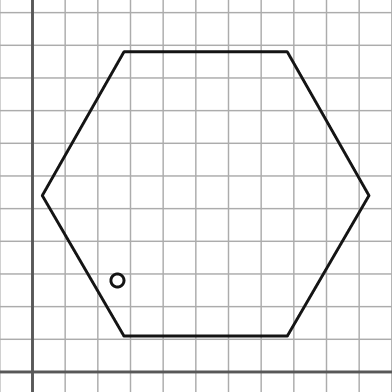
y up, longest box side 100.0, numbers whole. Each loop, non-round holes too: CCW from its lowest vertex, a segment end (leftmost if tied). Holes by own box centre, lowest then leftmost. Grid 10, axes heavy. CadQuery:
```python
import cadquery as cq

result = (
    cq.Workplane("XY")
    .moveTo(28.0, 11.0)
    .lineTo(78.0, 11.0)
    .lineTo(103.0, 54.0)
    .lineTo(78.0, 98.0)
    .lineTo(28.0, 98.0)
    .lineTo(3.0, 54.0)
    .close()
    .moveTo(26.0, 28.0)
    .circle(2.0)
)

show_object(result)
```